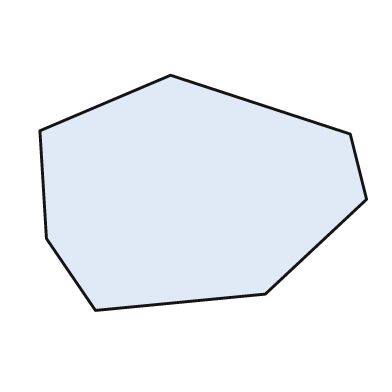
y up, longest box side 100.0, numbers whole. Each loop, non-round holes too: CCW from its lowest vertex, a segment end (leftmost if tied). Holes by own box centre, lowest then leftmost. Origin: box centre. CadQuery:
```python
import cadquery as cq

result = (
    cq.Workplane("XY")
    .moveTo(-33.0, -36.0)
    .lineTo(19.0, -31.0)
    .lineTo(50.0, -2.0)
    .lineTo(45.0, 18.0)
    .lineTo(-10.0, 36.0)
    .lineTo(-50.0, 19.0)
    .lineTo(-48.0, -14.0)
    .close()
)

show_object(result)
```